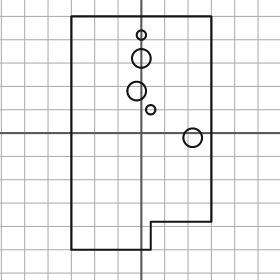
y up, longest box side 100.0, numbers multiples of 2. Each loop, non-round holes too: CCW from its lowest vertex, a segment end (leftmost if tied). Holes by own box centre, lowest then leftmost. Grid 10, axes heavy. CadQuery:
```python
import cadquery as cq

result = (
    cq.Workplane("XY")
    .moveTo(-30.0, -50.0)
    .lineTo(4.0, -50.0)
    .lineTo(4.0, -38.0)
    .lineTo(30.0, -38.0)
    .lineTo(30.0, 50.0)
    .lineTo(-30.0, 50.0)
    .close()
    .moveTo(22.0, -2.0)
    .circle(4.0)
    .moveTo(4.0, 10.0)
    .circle(2.0)
    .moveTo(-2.0, 18.0)
    .circle(4.0)
    .moveTo(0.0, 32.0)
    .circle(4.0)
    .moveTo(0.0, 42.0)
    .circle(2.0)
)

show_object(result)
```